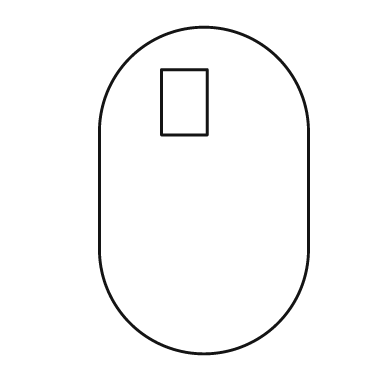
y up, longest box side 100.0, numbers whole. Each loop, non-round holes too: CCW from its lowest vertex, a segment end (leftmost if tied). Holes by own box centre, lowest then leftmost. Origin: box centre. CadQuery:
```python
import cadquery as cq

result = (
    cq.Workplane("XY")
    .moveTo(-32.0, -18.0)
    .threePointArc((0.0, -50.0), (32.0, -18.0))
    .lineTo(32.0, 18.0)
    .threePointArc((0.0, 50.0), (-32.0, 18.0))
    .close()
    .moveTo(-13.0, 17.0)
    .lineTo(1.0, 17.0)
    .lineTo(1.0, 37.0)
    .lineTo(-13.0, 37.0)
    .close()
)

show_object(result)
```